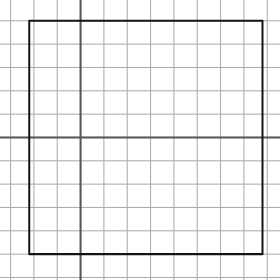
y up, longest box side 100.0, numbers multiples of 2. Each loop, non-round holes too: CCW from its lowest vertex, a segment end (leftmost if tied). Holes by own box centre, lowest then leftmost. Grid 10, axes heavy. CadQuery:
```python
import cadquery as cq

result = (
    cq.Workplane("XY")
    .moveTo(-22.0, -50.0)
    .lineTo(78.0, -50.0)
    .lineTo(78.0, 50.0)
    .lineTo(-22.0, 50.0)
    .close()
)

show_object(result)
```